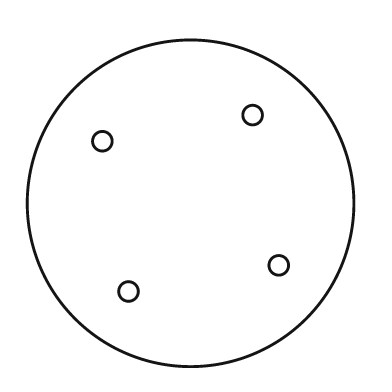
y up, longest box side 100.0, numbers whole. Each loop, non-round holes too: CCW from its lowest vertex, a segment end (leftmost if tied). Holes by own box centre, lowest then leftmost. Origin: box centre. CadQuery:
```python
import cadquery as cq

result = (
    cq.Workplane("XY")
    .moveTo(0.0, 0.0)
    .circle(50.0)
    .moveTo(-19.0, -27.0)
    .circle(3.0)
    .moveTo(27.0, -19.0)
    .circle(3.0)
    .moveTo(-27.0, 19.0)
    .circle(3.0)
    .moveTo(19.0, 27.0)
    .circle(3.0)
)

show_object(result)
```